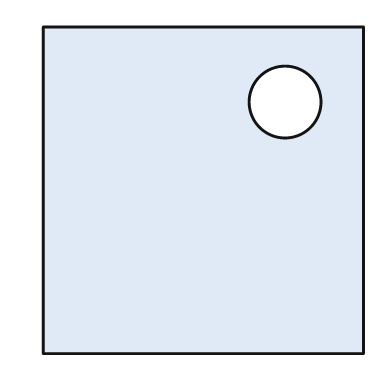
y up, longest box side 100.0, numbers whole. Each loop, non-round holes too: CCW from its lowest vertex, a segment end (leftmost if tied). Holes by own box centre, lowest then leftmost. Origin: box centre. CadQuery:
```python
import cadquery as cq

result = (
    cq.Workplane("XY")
    .moveTo(-49.0, -50.0)
    .lineTo(49.0, -50.0)
    .lineTo(49.0, 50.0)
    .lineTo(-49.0, 50.0)
    .close()
    .moveTo(25.0, 27.0)
    .circle(11.0)
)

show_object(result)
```